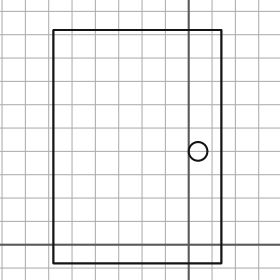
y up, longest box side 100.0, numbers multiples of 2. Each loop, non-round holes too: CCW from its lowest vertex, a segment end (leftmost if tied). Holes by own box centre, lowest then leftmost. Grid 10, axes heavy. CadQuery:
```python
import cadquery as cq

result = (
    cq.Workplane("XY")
    .moveTo(-58.0, -8.0)
    .lineTo(14.0, -8.0)
    .lineTo(14.0, 92.0)
    .lineTo(-58.0, 92.0)
    .close()
    .moveTo(4.0, 40.0)
    .circle(4.0)
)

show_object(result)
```